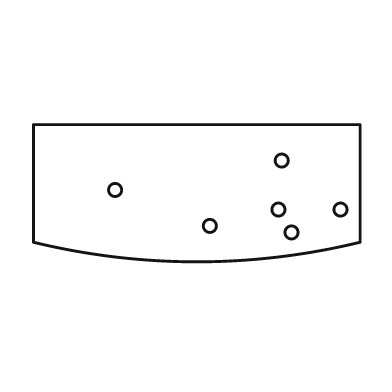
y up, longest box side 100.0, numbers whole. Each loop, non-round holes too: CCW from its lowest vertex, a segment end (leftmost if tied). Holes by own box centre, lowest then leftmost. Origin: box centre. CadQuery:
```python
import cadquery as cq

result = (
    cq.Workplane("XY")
    .moveTo(-50.0, -15.0)
    .threePointArc((0.0, -21.0), (50.0, -15.0))
    .lineTo(50.0, 21.0)
    .lineTo(-50.0, 21.0)
    .close()
    .moveTo(29.0, -12.0)
    .circle(2.0)
    .moveTo(4.0, -10.0)
    .circle(2.0)
    .moveTo(25.0, -5.0)
    .circle(2.0)
    .moveTo(44.0, -5.0)
    .circle(2.0)
    .moveTo(-25.0, 1.0)
    .circle(2.0)
    .moveTo(26.0, 10.0)
    .circle(2.0)
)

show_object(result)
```